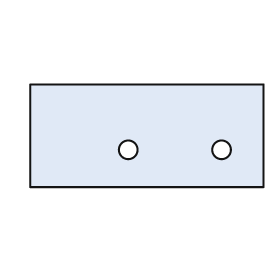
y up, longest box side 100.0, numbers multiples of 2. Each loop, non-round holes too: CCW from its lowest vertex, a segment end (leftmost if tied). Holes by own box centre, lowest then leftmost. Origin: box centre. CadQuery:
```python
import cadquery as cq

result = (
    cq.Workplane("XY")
    .moveTo(-50.0, -22.0)
    .lineTo(50.0, -22.0)
    .lineTo(50.0, 22.0)
    .lineTo(-50.0, 22.0)
    .close()
    .moveTo(-8.0, -6.0)
    .circle(4.0)
    .moveTo(32.0, -6.0)
    .circle(4.0)
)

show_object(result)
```